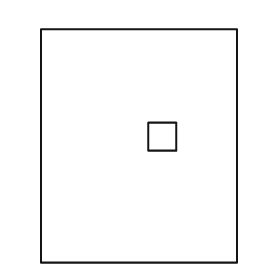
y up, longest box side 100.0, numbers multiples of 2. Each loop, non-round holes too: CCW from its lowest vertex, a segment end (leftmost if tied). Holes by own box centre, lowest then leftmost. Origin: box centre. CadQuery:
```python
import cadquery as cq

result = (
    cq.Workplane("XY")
    .moveTo(-42.0, -50.0)
    .lineTo(42.0, -50.0)
    .lineTo(42.0, 50.0)
    .lineTo(-42.0, 50.0)
    .close()
    .moveTo(4.0, -2.0)
    .lineTo(16.0, -2.0)
    .lineTo(16.0, 10.0)
    .lineTo(4.0, 10.0)
    .close()
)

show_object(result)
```